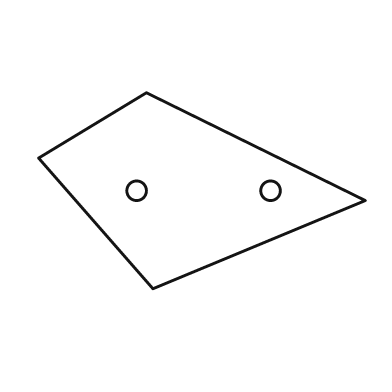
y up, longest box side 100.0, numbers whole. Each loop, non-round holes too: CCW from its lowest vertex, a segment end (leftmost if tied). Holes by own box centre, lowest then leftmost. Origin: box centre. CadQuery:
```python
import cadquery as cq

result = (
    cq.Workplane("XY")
    .moveTo(-15.0, -30.0)
    .lineTo(50.0, -3.0)
    .lineTo(-17.0, 30.0)
    .lineTo(-50.0, 10.0)
    .close()
    .moveTo(-20.0, 0.0)
    .circle(3.0)
    .moveTo(21.0, 0.0)
    .circle(3.0)
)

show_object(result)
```